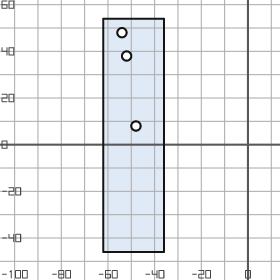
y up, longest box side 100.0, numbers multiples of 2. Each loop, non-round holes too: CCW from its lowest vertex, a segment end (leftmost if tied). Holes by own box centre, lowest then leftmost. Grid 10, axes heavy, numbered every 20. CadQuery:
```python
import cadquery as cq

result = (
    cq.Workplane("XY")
    .moveTo(-62.0, -46.0)
    .lineTo(-36.0, -46.0)
    .lineTo(-36.0, 54.0)
    .lineTo(-62.0, 54.0)
    .close()
    .moveTo(-48.0, 8.0)
    .circle(2.0)
    .moveTo(-52.0, 38.0)
    .circle(2.0)
    .moveTo(-54.0, 48.0)
    .circle(2.0)
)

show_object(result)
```